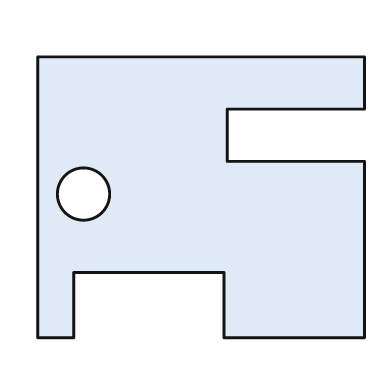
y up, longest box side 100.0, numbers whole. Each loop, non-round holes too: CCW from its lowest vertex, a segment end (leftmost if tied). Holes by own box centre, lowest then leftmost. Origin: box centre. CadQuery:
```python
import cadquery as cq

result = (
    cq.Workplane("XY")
    .moveTo(-50.0, -43.0)
    .lineTo(-39.0, -43.0)
    .lineTo(-39.0, -23.0)
    .lineTo(7.0, -23.0)
    .lineTo(7.0, -43.0)
    .lineTo(50.0, -43.0)
    .lineTo(50.0, 11.0)
    .lineTo(8.0, 11.0)
    .lineTo(8.0, 27.0)
    .lineTo(50.0, 27.0)
    .lineTo(50.0, 43.0)
    .lineTo(-50.0, 43.0)
    .close()
    .moveTo(-36.0, 1.0)
    .circle(8.0)
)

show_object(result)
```